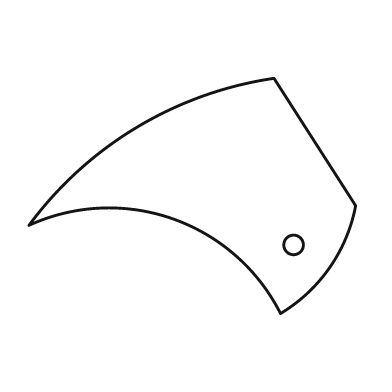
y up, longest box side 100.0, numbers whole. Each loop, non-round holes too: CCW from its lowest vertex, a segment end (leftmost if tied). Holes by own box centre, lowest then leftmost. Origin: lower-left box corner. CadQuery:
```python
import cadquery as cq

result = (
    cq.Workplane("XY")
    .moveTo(77.0, 0.0)
    .threePointArc((92.0, 14.0), (100.0, 33.0))
    .lineTo(75.0, 72.0)
    .threePointArc((33.0, 57.0), (0.0, 27.0))
    .threePointArc((44.0, 29.0), (77.0, 0.0))
    .close()
    .moveTo(81.0, 21.0)
    .circle(3.0)
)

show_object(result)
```